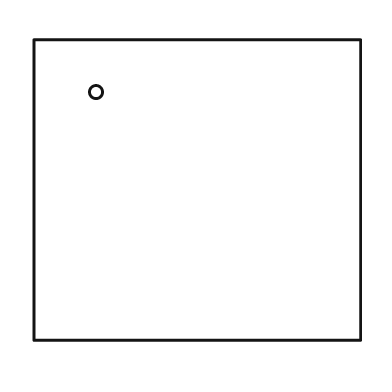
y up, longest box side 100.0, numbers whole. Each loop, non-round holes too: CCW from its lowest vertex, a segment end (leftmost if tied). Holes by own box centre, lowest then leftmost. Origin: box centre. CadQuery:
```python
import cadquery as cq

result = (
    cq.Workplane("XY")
    .moveTo(-50.0, -46.0)
    .lineTo(50.0, -46.0)
    .lineTo(50.0, 46.0)
    .lineTo(-50.0, 46.0)
    .close()
    .moveTo(-31.0, 30.0)
    .circle(2.0)
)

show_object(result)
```